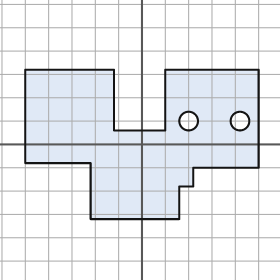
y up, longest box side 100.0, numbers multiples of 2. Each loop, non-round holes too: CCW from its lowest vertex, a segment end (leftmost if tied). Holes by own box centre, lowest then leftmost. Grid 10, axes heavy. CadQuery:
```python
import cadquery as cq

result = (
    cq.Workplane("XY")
    .moveTo(-22.0, -32.0)
    .lineTo(16.0, -32.0)
    .lineTo(16.0, -18.0)
    .lineTo(22.0, -18.0)
    .lineTo(22.0, -10.0)
    .lineTo(50.0, -10.0)
    .lineTo(50.0, 32.0)
    .lineTo(10.0, 32.0)
    .lineTo(10.0, 6.0)
    .lineTo(-12.0, 6.0)
    .lineTo(-12.0, 32.0)
    .lineTo(-50.0, 32.0)
    .lineTo(-50.0, -8.0)
    .lineTo(-22.0, -8.0)
    .close()
    .moveTo(20.0, 10.0)
    .circle(4.0)
    .moveTo(42.0, 10.0)
    .circle(4.0)
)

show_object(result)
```